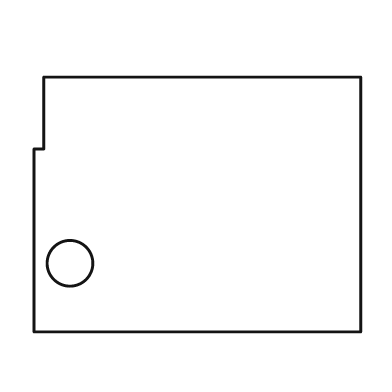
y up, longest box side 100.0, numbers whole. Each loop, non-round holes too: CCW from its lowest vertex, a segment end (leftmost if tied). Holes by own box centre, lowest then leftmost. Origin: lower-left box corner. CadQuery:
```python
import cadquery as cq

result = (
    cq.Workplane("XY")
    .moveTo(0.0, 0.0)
    .lineTo(100.0, 0.0)
    .lineTo(100.0, 78.0)
    .lineTo(3.0, 78.0)
    .lineTo(3.0, 56.0)
    .lineTo(0.0, 56.0)
    .close()
    .moveTo(11.0, 21.0)
    .circle(7.0)
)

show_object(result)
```